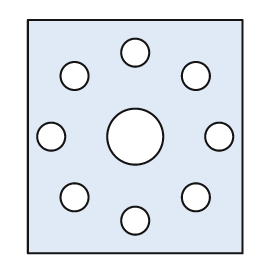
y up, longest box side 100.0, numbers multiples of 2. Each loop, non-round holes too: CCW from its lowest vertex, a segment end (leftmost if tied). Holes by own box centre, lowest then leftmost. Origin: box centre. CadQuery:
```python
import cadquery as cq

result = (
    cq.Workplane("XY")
    .moveTo(-46.0, -50.0)
    .lineTo(46.0, -50.0)
    .lineTo(46.0, 50.0)
    .lineTo(-46.0, 50.0)
    .close()
    .moveTo(0.0, -36.0)
    .circle(6.0)
    .moveTo(-26.0, -26.0)
    .circle(6.0)
    .moveTo(26.0, -26.0)
    .circle(6.0)
    .moveTo(-36.0, 0.0)
    .circle(6.0)
    .moveTo(0.0, 0.0)
    .circle(12.0)
    .moveTo(36.0, 0.0)
    .circle(6.0)
    .moveTo(-26.0, 26.0)
    .circle(6.0)
    .moveTo(26.0, 26.0)
    .circle(6.0)
    .moveTo(0.0, 36.0)
    .circle(6.0)
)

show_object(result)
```